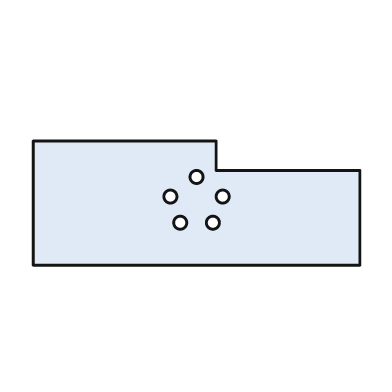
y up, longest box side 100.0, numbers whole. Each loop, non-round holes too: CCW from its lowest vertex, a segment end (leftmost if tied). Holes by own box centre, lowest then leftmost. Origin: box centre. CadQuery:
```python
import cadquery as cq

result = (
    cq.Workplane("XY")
    .moveTo(-50.0, -19.0)
    .lineTo(50.0, -19.0)
    .lineTo(50.0, 10.0)
    .lineTo(6.0, 10.0)
    .lineTo(6.0, 19.0)
    .lineTo(-50.0, 19.0)
    .close()
    .moveTo(-5.0, -6.0)
    .circle(2.0)
    .moveTo(5.0, -6.0)
    .circle(2.0)
    .moveTo(-8.0, 2.0)
    .circle(2.0)
    .moveTo(8.0, 2.0)
    .circle(2.0)
    .moveTo(0.0, 8.0)
    .circle(2.0)
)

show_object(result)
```